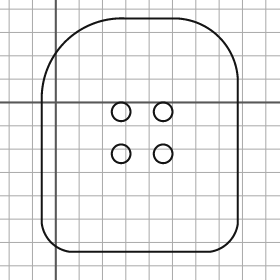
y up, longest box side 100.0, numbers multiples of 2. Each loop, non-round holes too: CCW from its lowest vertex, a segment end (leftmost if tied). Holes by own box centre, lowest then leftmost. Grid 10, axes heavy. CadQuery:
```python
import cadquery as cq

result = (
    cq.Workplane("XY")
    .moveTo(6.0, -64.0)
    .lineTo(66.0, -64.0)
    .threePointArc((74.0, -60.0), (78.0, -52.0))
    .lineTo(78.0, 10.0)
    .threePointArc((70.0, 28.0), (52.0, 36.0))
    .lineTo(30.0, 36.0)
    .threePointArc((4.0, 26.0), (-6.0, 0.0))
    .lineTo(-6.0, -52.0)
    .threePointArc((-2.0, -60.0), (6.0, -64.0))
    .close()
    .moveTo(28.0, -22.0)
    .circle(4.0)
    .moveTo(46.0, -22.0)
    .circle(4.0)
    .moveTo(28.0, -4.0)
    .circle(4.0)
    .moveTo(46.0, -4.0)
    .circle(4.0)
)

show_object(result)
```